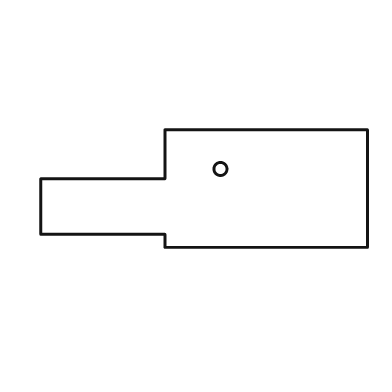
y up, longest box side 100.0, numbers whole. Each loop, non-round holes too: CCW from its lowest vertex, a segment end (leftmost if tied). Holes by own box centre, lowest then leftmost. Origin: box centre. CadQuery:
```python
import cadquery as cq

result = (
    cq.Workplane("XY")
    .moveTo(-12.0, -18.0)
    .lineTo(50.0, -18.0)
    .lineTo(50.0, 18.0)
    .lineTo(-12.0, 18.0)
    .lineTo(-12.0, 3.0)
    .lineTo(-50.0, 3.0)
    .lineTo(-50.0, -14.0)
    .lineTo(-12.0, -14.0)
    .close()
    .moveTo(5.0, 6.0)
    .circle(2.0)
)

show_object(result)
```